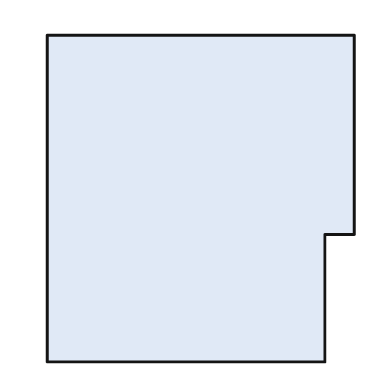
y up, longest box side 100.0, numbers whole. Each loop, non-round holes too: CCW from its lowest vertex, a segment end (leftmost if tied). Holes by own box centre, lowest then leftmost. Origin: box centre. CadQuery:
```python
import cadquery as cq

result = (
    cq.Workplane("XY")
    .moveTo(-47.0, -50.0)
    .lineTo(38.0, -50.0)
    .lineTo(38.0, -11.0)
    .lineTo(47.0, -11.0)
    .lineTo(47.0, 50.0)
    .lineTo(-47.0, 50.0)
    .close()
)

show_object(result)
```